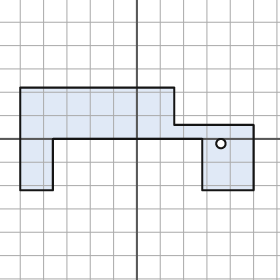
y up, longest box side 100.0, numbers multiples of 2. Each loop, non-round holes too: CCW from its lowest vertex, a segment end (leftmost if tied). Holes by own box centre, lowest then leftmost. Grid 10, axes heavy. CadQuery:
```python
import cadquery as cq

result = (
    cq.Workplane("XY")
    .moveTo(-50.0, -22.0)
    .lineTo(-36.0, -22.0)
    .lineTo(-36.0, 0.0)
    .lineTo(28.0, 0.0)
    .lineTo(28.0, -22.0)
    .lineTo(50.0, -22.0)
    .lineTo(50.0, 6.0)
    .lineTo(16.0, 6.0)
    .lineTo(16.0, 22.0)
    .lineTo(-50.0, 22.0)
    .close()
    .moveTo(36.0, -2.0)
    .circle(2.0)
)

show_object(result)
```